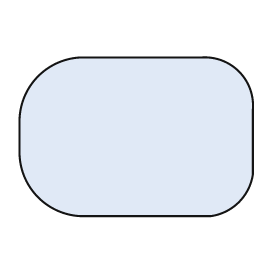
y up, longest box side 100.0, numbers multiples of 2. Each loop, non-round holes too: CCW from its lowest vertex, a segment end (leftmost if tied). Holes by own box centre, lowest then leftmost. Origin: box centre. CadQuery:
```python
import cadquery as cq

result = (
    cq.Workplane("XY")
    .moveTo(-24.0, -34.0)
    .lineTo(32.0, -34.0)
    .threePointArc((44.0, -28.0), (50.0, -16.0))
    .lineTo(50.0, 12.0)
    .threePointArc((44.0, 28.0), (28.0, 34.0))
    .lineTo(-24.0, 34.0)
    .threePointArc((-42.0, 26.0), (-50.0, 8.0))
    .lineTo(-50.0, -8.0)
    .threePointArc((-42.0, -26.0), (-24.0, -34.0))
    .close()
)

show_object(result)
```